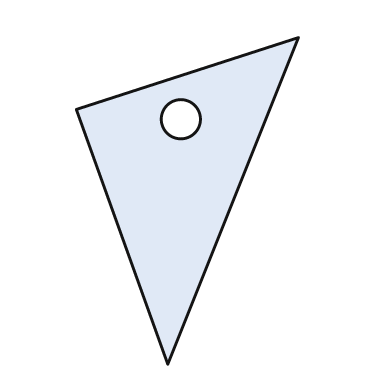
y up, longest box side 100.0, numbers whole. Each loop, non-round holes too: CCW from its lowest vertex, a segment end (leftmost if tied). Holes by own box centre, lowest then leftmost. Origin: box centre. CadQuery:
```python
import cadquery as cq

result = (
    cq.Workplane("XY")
    .moveTo(-6.0, -50.0)
    .lineTo(34.0, 50.0)
    .lineTo(-34.0, 28.0)
    .close()
    .moveTo(-2.0, 25.0)
    .circle(6.0)
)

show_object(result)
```